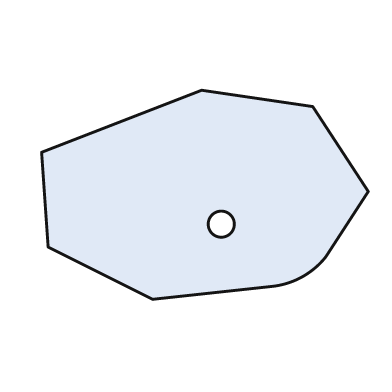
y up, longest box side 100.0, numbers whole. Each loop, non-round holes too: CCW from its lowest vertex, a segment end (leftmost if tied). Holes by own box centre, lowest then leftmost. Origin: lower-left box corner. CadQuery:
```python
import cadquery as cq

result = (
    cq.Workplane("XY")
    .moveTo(34.0, 0.0)
    .lineTo(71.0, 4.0)
    .threePointArc((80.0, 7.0), (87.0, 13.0))
    .lineTo(100.0, 33.0)
    .lineTo(83.0, 59.0)
    .lineTo(49.0, 64.0)
    .lineTo(0.0, 45.0)
    .lineTo(2.0, 16.0)
    .close()
    .moveTo(55.0, 23.0)
    .circle(4.0)
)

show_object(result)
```